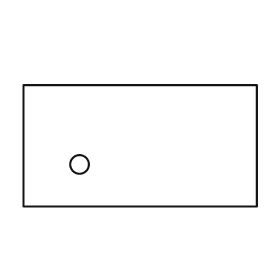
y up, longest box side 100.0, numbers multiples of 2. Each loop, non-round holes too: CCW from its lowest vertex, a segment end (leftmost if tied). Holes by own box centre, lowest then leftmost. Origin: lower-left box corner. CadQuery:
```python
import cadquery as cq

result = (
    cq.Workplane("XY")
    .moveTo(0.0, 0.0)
    .lineTo(100.0, 0.0)
    .lineTo(100.0, 52.0)
    .lineTo(0.0, 52.0)
    .close()
    .moveTo(24.0, 18.0)
    .circle(4.0)
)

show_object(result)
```